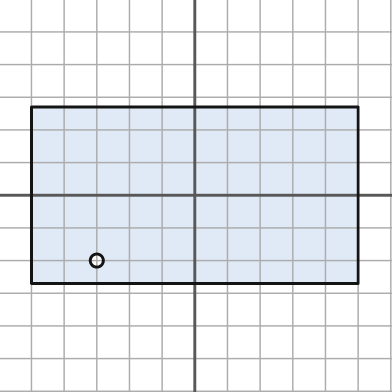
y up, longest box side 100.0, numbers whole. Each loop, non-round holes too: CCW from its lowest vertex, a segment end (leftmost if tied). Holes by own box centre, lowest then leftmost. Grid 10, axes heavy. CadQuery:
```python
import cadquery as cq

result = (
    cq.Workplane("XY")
    .moveTo(-50.0, -27.0)
    .lineTo(50.0, -27.0)
    .lineTo(50.0, 27.0)
    .lineTo(-50.0, 27.0)
    .close()
    .moveTo(-30.0, -20.0)
    .circle(2.0)
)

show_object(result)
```